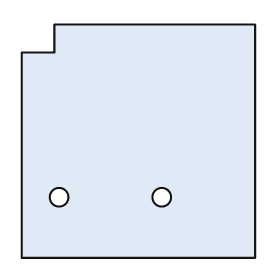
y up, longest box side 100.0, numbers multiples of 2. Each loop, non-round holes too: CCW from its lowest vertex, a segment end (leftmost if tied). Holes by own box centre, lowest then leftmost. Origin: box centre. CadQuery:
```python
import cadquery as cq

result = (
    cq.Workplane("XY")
    .moveTo(-50.0, -50.0)
    .lineTo(50.0, -50.0)
    .lineTo(50.0, 50.0)
    .lineTo(-36.0, 50.0)
    .lineTo(-36.0, 38.0)
    .lineTo(-50.0, 38.0)
    .close()
    .moveTo(-34.0, -24.0)
    .circle(4.0)
    .moveTo(10.0, -24.0)
    .circle(4.0)
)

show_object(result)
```